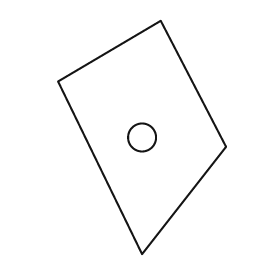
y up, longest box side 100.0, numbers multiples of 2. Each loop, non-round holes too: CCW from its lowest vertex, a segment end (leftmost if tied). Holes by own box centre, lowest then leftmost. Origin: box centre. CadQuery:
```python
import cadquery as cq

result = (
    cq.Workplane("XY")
    .moveTo(0.0, -50.0)
    .lineTo(36.0, -4.0)
    .lineTo(8.0, 50.0)
    .lineTo(-36.0, 24.0)
    .close()
    .moveTo(0.0, 0.0)
    .circle(6.0)
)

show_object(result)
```